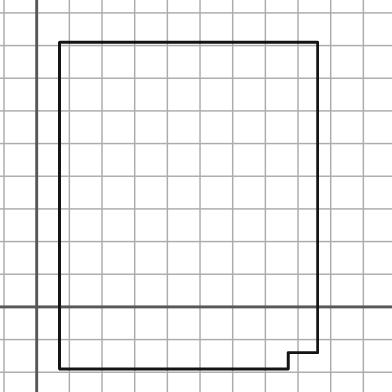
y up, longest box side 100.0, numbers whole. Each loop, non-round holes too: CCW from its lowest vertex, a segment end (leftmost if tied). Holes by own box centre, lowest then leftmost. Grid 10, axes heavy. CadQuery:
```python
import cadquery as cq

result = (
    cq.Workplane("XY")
    .moveTo(7.0, -19.0)
    .lineTo(77.0, -19.0)
    .lineTo(77.0, -14.0)
    .lineTo(86.0, -14.0)
    .lineTo(86.0, 81.0)
    .lineTo(7.0, 81.0)
    .close()
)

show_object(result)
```